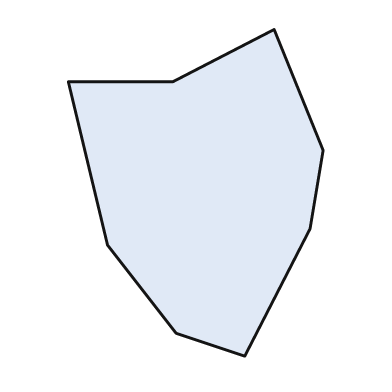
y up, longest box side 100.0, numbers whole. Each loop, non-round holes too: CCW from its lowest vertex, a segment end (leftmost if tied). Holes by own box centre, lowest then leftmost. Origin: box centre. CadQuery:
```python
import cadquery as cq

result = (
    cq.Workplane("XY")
    .moveTo(15.0, -50.0)
    .lineTo(35.0, -11.0)
    .lineTo(39.0, 13.0)
    .lineTo(24.0, 50.0)
    .lineTo(-7.0, 34.0)
    .lineTo(-39.0, 34.0)
    .lineTo(-27.0, -16.0)
    .lineTo(-6.0, -43.0)
    .close()
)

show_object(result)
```